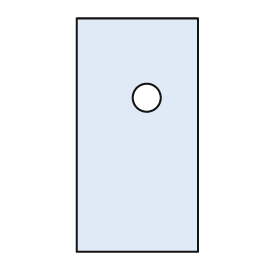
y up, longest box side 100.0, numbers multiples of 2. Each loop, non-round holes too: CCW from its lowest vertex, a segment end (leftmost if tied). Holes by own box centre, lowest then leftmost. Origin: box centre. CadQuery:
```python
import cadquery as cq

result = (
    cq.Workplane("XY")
    .moveTo(-26.0, -50.0)
    .lineTo(26.0, -50.0)
    .lineTo(26.0, 50.0)
    .lineTo(-26.0, 50.0)
    .close()
    .moveTo(4.0, 16.0)
    .circle(6.0)
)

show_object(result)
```